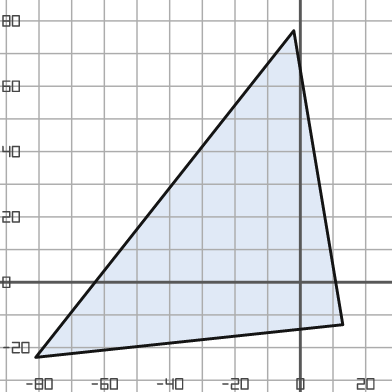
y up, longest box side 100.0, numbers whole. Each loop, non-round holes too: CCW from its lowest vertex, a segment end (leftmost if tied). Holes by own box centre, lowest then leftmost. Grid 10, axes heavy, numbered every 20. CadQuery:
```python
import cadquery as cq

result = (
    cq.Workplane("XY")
    .moveTo(-81.0, -23.0)
    .lineTo(13.0, -13.0)
    .lineTo(-2.0, 77.0)
    .close()
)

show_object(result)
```